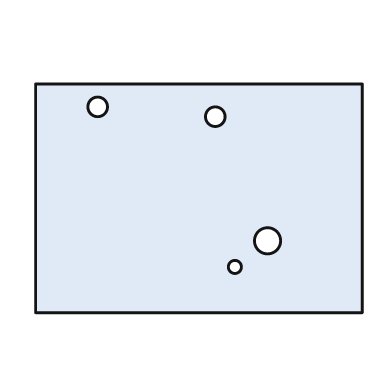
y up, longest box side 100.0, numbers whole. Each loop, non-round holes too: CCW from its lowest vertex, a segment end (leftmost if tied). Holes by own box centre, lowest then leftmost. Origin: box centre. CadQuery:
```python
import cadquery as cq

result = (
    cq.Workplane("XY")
    .moveTo(-50.0, -35.0)
    .lineTo(50.0, -35.0)
    .lineTo(50.0, 35.0)
    .lineTo(-50.0, 35.0)
    .close()
    .moveTo(11.0, -21.0)
    .circle(2.0)
    .moveTo(21.0, -13.0)
    .circle(4.0)
    .moveTo(5.0, 25.0)
    .circle(3.0)
    .moveTo(-31.0, 28.0)
    .circle(3.0)
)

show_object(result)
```